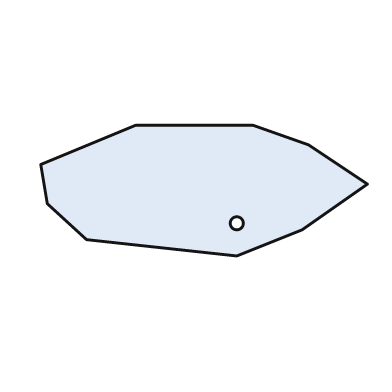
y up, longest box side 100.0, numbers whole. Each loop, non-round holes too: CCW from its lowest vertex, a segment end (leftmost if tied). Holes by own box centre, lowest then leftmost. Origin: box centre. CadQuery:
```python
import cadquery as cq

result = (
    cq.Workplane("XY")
    .moveTo(10.0, -20.0)
    .lineTo(30.0, -12.0)
    .lineTo(50.0, 2.0)
    .lineTo(32.0, 14.0)
    .lineTo(15.0, 20.0)
    .lineTo(-21.0, 20.0)
    .lineTo(-50.0, 8.0)
    .lineTo(-48.0, -4.0)
    .lineTo(-36.0, -15.0)
    .close()
    .moveTo(10.0, -10.0)
    .circle(2.0)
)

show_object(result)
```